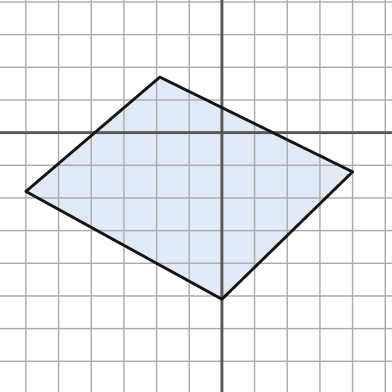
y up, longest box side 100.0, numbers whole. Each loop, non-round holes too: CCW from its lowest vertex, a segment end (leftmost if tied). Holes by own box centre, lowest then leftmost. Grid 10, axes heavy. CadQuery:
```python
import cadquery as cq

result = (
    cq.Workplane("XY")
    .moveTo(0.0, -51.0)
    .lineTo(40.0, -12.0)
    .lineTo(-19.0, 17.0)
    .lineTo(-60.0, -18.0)
    .close()
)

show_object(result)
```